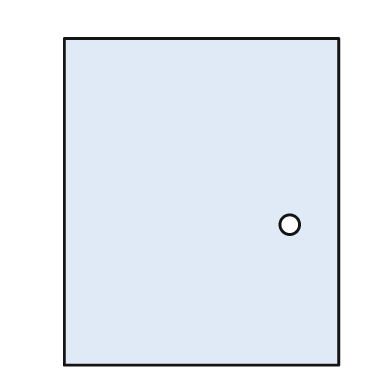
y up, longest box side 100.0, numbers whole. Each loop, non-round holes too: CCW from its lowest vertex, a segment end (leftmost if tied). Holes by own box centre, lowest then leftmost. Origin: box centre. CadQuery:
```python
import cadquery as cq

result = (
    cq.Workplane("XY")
    .moveTo(-42.0, -50.0)
    .lineTo(42.0, -50.0)
    .lineTo(42.0, 50.0)
    .lineTo(-42.0, 50.0)
    .close()
    .moveTo(27.0, -7.0)
    .circle(3.0)
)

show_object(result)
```